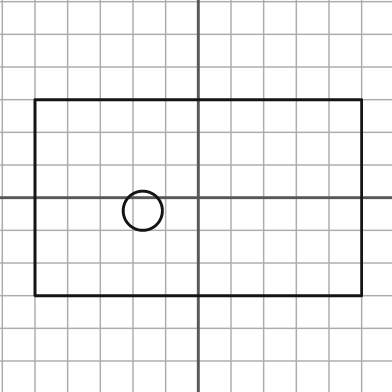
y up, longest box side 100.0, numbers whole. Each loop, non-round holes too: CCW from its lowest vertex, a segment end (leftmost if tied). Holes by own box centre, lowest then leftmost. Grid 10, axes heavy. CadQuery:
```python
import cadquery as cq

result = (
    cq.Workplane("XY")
    .moveTo(-50.0, -30.0)
    .lineTo(50.0, -30.0)
    .lineTo(50.0, 30.0)
    .lineTo(-50.0, 30.0)
    .close()
    .moveTo(-17.0, -4.0)
    .circle(6.0)
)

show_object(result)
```